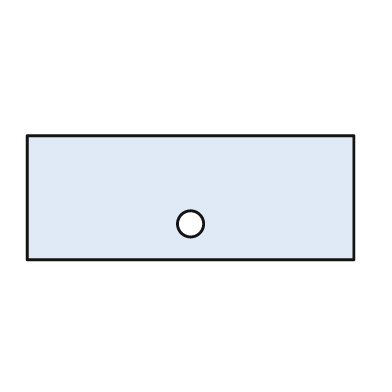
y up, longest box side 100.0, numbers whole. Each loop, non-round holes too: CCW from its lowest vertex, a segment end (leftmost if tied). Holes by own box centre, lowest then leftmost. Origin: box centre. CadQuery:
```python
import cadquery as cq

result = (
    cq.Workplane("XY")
    .moveTo(-50.0, -19.0)
    .lineTo(50.0, -19.0)
    .lineTo(50.0, 19.0)
    .lineTo(-50.0, 19.0)
    .close()
    .moveTo(0.0, -8.0)
    .circle(4.0)
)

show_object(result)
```